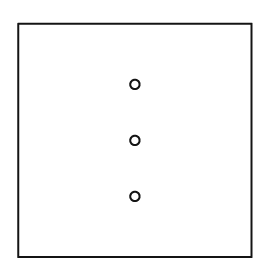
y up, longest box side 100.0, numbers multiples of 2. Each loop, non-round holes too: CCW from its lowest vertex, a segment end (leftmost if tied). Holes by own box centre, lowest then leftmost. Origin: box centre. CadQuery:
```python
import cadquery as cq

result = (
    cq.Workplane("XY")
    .moveTo(-50.0, -50.0)
    .lineTo(50.0, -50.0)
    .lineTo(50.0, 50.0)
    .lineTo(-50.0, 50.0)
    .close()
    .moveTo(0.0, -24.0)
    .circle(2.0)
    .moveTo(0.0, 0.0)
    .circle(2.0)
    .moveTo(0.0, 24.0)
    .circle(2.0)
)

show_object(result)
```